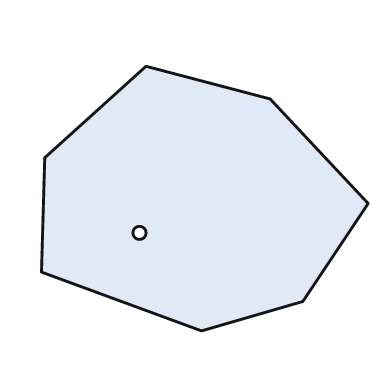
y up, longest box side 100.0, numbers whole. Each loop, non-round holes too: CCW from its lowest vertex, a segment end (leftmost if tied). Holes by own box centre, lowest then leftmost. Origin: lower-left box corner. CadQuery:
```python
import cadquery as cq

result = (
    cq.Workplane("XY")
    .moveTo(49.0, 0.0)
    .lineTo(80.0, 9.0)
    .lineTo(100.0, 39.0)
    .lineTo(70.0, 71.0)
    .lineTo(32.0, 81.0)
    .lineTo(1.0, 53.0)
    .lineTo(0.0, 18.0)
    .close()
    .moveTo(30.0, 30.0)
    .circle(2.0)
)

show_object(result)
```